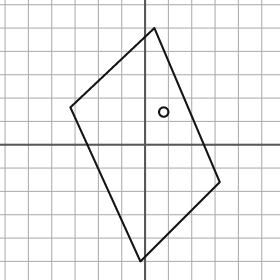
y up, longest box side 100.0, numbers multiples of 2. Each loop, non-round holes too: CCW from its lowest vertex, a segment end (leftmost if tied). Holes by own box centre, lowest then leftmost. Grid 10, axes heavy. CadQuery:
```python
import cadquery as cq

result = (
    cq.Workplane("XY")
    .moveTo(-2.0, -50.0)
    .lineTo(32.0, -16.0)
    .lineTo(4.0, 50.0)
    .lineTo(-32.0, 16.0)
    .close()
    .moveTo(8.0, 14.0)
    .circle(2.0)
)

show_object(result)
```